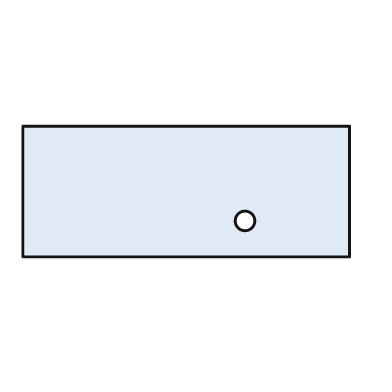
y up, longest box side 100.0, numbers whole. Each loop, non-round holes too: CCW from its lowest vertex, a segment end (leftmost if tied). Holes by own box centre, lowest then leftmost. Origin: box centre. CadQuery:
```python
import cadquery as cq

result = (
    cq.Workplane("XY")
    .moveTo(-50.0, -20.0)
    .lineTo(50.0, -20.0)
    .lineTo(50.0, 20.0)
    .lineTo(-50.0, 20.0)
    .close()
    .moveTo(18.0, -9.0)
    .circle(3.0)
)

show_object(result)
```